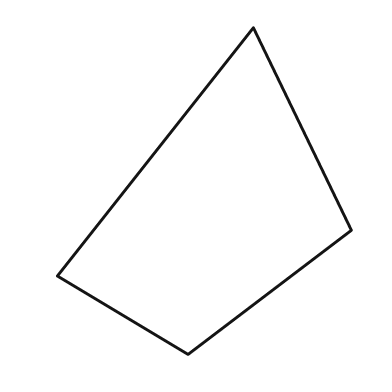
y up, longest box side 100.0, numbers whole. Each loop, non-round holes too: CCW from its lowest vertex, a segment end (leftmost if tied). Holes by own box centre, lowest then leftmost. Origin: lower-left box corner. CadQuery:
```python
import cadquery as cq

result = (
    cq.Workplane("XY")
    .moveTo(40.0, 0.0)
    .lineTo(90.0, 38.0)
    .lineTo(60.0, 100.0)
    .lineTo(0.0, 24.0)
    .close()
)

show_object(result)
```